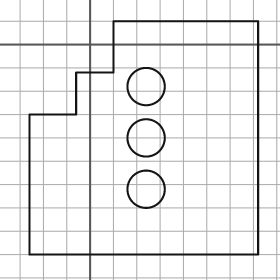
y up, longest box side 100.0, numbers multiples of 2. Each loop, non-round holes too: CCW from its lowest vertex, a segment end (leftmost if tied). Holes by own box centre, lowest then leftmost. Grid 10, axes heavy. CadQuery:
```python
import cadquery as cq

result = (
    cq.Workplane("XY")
    .moveTo(-26.0, -90.0)
    .lineTo(72.0, -90.0)
    .lineTo(72.0, 10.0)
    .lineTo(10.0, 10.0)
    .lineTo(10.0, -12.0)
    .lineTo(-6.0, -12.0)
    .lineTo(-6.0, -30.0)
    .lineTo(-26.0, -30.0)
    .close()
    .moveTo(24.0, -62.0)
    .circle(8.0)
    .moveTo(24.0, -40.0)
    .circle(8.0)
    .moveTo(24.0, -18.0)
    .circle(8.0)
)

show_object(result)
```